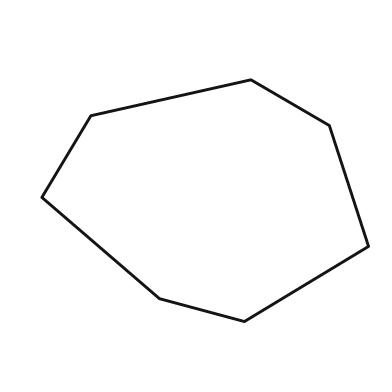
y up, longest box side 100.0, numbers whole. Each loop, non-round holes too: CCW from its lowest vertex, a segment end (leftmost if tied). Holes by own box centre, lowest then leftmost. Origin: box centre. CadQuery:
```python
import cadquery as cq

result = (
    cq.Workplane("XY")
    .moveTo(12.0, -37.0)
    .lineTo(50.0, -14.0)
    .lineTo(38.0, 23.0)
    .lineTo(14.0, 37.0)
    .lineTo(-35.0, 26.0)
    .lineTo(-50.0, 1.0)
    .lineTo(-14.0, -30.0)
    .close()
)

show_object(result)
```